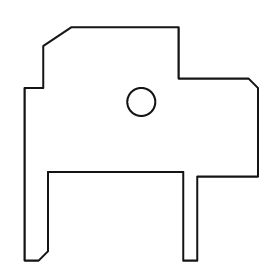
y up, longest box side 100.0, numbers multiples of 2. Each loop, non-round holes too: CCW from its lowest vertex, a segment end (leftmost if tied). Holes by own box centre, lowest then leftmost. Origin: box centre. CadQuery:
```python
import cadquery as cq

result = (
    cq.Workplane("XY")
    .moveTo(-50.0, -50.0)
    .lineTo(-44.0, -50.0)
    .lineTo(-40.0, -46.0)
    .lineTo(-40.0, -12.0)
    .lineTo(18.0, -12.0)
    .lineTo(18.0, -50.0)
    .lineTo(24.0, -50.0)
    .lineTo(24.0, -14.0)
    .lineTo(50.0, -14.0)
    .lineTo(50.0, 24.0)
    .lineTo(46.0, 28.0)
    .lineTo(16.0, 28.0)
    .lineTo(16.0, 50.0)
    .lineTo(-30.0, 50.0)
    .lineTo(-42.0, 42.0)
    .lineTo(-42.0, 24.0)
    .lineTo(-50.0, 24.0)
    .close()
    .moveTo(0.0, 18.0)
    .circle(6.0)
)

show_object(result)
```